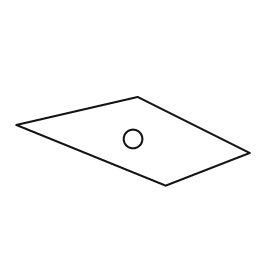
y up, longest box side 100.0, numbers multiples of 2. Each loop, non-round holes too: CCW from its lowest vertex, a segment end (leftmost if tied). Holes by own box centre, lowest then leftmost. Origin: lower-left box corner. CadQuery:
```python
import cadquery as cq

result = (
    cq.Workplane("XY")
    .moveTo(64.0, 0.0)
    .lineTo(100.0, 14.0)
    .lineTo(52.0, 38.0)
    .lineTo(0.0, 26.0)
    .close()
    .moveTo(50.0, 20.0)
    .circle(4.0)
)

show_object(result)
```